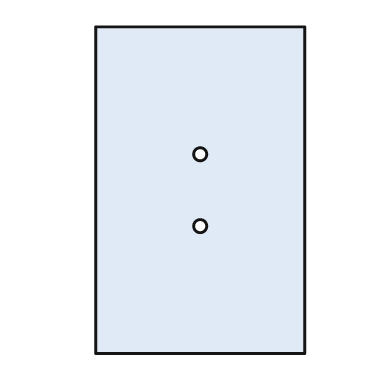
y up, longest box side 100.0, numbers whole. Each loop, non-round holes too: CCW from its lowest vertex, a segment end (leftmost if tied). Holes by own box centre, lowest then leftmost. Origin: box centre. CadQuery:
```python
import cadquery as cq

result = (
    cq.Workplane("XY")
    .moveTo(-32.0, -50.0)
    .lineTo(32.0, -50.0)
    .lineTo(32.0, 50.0)
    .lineTo(-32.0, 50.0)
    .close()
    .moveTo(0.0, -11.0)
    .circle(2.0)
    .moveTo(0.0, 11.0)
    .circle(2.0)
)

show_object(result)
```